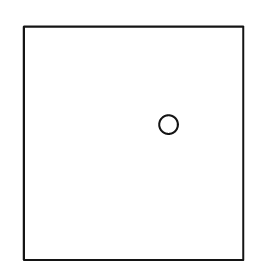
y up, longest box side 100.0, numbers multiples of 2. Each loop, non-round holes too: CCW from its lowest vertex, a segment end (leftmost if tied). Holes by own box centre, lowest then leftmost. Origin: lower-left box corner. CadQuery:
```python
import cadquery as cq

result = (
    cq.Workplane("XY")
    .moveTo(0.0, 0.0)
    .lineTo(94.0, 0.0)
    .lineTo(94.0, 100.0)
    .lineTo(0.0, 100.0)
    .close()
    .moveTo(62.0, 58.0)
    .circle(4.0)
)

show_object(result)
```